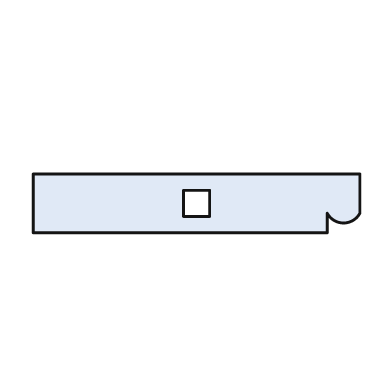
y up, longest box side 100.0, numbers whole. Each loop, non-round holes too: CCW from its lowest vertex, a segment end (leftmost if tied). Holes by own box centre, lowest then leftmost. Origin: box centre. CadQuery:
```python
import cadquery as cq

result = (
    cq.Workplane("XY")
    .moveTo(-50.0, -9.0)
    .lineTo(40.0, -9.0)
    .lineTo(40.0, -3.0)
    .threePointArc((45.0, -6.0), (50.0, -3.0))
    .lineTo(50.0, 9.0)
    .lineTo(-50.0, 9.0)
    .close()
    .moveTo(-4.0, -4.0)
    .lineTo(4.0, -4.0)
    .lineTo(4.0, 4.0)
    .lineTo(-4.0, 4.0)
    .close()
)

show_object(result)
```